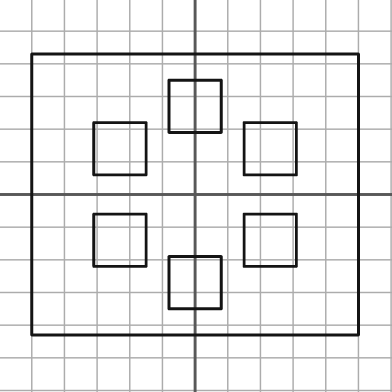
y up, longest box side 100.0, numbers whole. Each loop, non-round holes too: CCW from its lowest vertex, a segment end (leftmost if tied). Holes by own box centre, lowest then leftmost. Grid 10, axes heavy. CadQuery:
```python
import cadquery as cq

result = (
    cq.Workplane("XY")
    .moveTo(-50.0, -43.0)
    .lineTo(50.0, -43.0)
    .lineTo(50.0, 43.0)
    .lineTo(-50.0, 43.0)
    .close()
    .moveTo(-8.0, -35.0)
    .lineTo(8.0, -35.0)
    .lineTo(8.0, -19.0)
    .lineTo(-8.0, -19.0)
    .close()
    .moveTo(-31.0, -22.0)
    .lineTo(-15.0, -22.0)
    .lineTo(-15.0, -6.0)
    .lineTo(-31.0, -6.0)
    .close()
    .moveTo(15.0, -22.0)
    .lineTo(31.0, -22.0)
    .lineTo(31.0, -6.0)
    .lineTo(15.0, -6.0)
    .close()
    .moveTo(-31.0, 6.0)
    .lineTo(-15.0, 6.0)
    .lineTo(-15.0, 22.0)
    .lineTo(-31.0, 22.0)
    .close()
    .moveTo(15.0, 6.0)
    .lineTo(31.0, 6.0)
    .lineTo(31.0, 22.0)
    .lineTo(15.0, 22.0)
    .close()
    .moveTo(-8.0, 19.0)
    .lineTo(8.0, 19.0)
    .lineTo(8.0, 35.0)
    .lineTo(-8.0, 35.0)
    .close()
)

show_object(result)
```